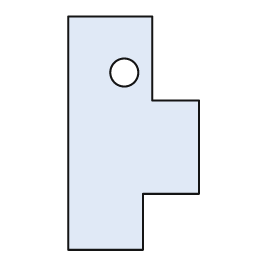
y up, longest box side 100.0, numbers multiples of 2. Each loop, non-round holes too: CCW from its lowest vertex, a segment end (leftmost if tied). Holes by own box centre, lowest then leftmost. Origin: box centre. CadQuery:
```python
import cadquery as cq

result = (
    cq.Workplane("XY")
    .moveTo(-28.0, -50.0)
    .lineTo(4.0, -50.0)
    .lineTo(4.0, -26.0)
    .lineTo(28.0, -26.0)
    .lineTo(28.0, 14.0)
    .lineTo(8.0, 14.0)
    .lineTo(8.0, 50.0)
    .lineTo(-28.0, 50.0)
    .close()
    .moveTo(-4.0, 26.0)
    .circle(6.0)
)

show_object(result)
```